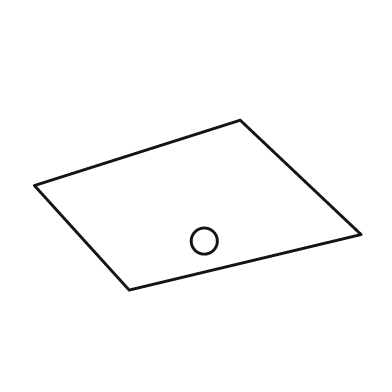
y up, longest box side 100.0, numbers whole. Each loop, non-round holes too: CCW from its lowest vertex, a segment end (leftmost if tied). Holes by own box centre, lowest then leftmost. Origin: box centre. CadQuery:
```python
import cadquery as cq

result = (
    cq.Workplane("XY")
    .moveTo(-21.0, -26.0)
    .lineTo(50.0, -9.0)
    .lineTo(13.0, 26.0)
    .lineTo(-50.0, 6.0)
    .close()
    .moveTo(2.0, -11.0)
    .circle(4.0)
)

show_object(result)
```